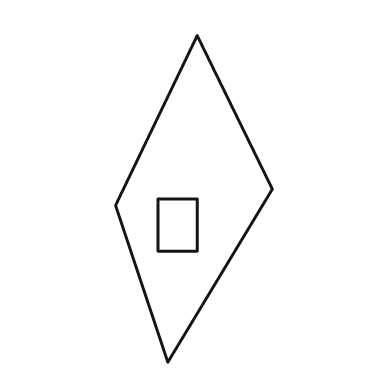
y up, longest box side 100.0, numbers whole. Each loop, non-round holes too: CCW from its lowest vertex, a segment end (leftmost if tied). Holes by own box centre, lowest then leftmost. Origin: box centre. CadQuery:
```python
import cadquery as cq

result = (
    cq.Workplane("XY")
    .moveTo(-8.0, -50.0)
    .lineTo(24.0, 3.0)
    .lineTo(1.0, 50.0)
    .lineTo(-24.0, -2.0)
    .close()
    .moveTo(-11.0, -16.0)
    .lineTo(1.0, -16.0)
    .lineTo(1.0, 0.0)
    .lineTo(-11.0, 0.0)
    .close()
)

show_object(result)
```